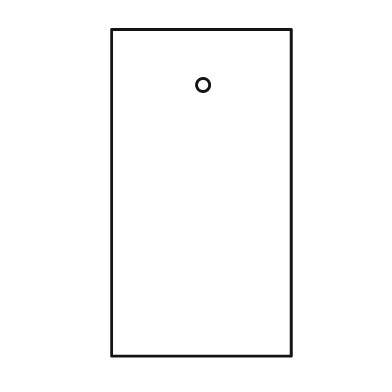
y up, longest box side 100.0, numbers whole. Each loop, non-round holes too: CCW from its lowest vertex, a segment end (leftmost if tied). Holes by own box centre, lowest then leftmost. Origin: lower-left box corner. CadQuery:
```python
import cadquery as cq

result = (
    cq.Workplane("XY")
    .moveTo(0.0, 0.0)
    .lineTo(55.0, 0.0)
    .lineTo(55.0, 100.0)
    .lineTo(0.0, 100.0)
    .close()
    .moveTo(28.0, 83.0)
    .circle(2.0)
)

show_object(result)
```